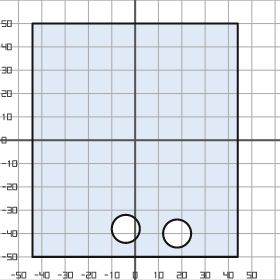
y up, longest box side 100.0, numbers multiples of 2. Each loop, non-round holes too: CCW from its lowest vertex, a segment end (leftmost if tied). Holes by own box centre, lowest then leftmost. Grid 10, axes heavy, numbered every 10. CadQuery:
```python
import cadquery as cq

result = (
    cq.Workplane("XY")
    .moveTo(-44.0, -50.0)
    .lineTo(44.0, -50.0)
    .lineTo(44.0, 50.0)
    .lineTo(-44.0, 50.0)
    .close()
    .moveTo(18.0, -40.0)
    .circle(6.0)
    .moveTo(-4.0, -38.0)
    .circle(6.0)
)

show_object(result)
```